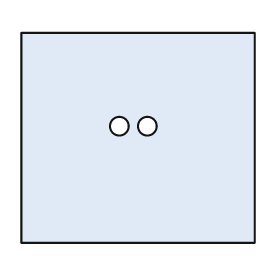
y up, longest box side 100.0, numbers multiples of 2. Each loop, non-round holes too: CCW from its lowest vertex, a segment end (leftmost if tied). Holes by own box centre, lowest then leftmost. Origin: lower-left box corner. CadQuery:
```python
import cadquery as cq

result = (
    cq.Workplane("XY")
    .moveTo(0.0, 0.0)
    .lineTo(100.0, 0.0)
    .lineTo(100.0, 90.0)
    .lineTo(0.0, 90.0)
    .close()
    .moveTo(42.0, 50.0)
    .circle(4.0)
    .moveTo(54.0, 50.0)
    .circle(4.0)
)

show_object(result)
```